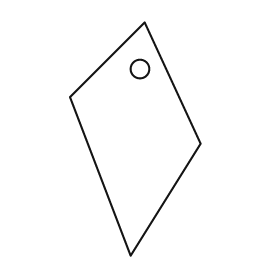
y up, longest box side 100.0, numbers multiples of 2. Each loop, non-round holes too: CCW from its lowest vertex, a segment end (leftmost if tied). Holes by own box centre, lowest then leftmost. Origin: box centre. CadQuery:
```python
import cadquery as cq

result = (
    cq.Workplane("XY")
    .moveTo(-2.0, -50.0)
    .lineTo(28.0, -2.0)
    .lineTo(4.0, 50.0)
    .lineTo(-28.0, 18.0)
    .close()
    .moveTo(2.0, 30.0)
    .circle(4.0)
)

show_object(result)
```